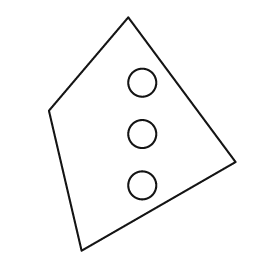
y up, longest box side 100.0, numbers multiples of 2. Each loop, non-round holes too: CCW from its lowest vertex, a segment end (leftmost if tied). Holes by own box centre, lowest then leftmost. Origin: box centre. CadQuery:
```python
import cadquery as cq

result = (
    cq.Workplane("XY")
    .moveTo(-26.0, -50.0)
    .lineTo(40.0, -12.0)
    .lineTo(-6.0, 50.0)
    .lineTo(-40.0, 10.0)
    .close()
    .moveTo(0.0, -22.0)
    .circle(6.0)
    .moveTo(0.0, 0.0)
    .circle(6.0)
    .moveTo(0.0, 22.0)
    .circle(6.0)
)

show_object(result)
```